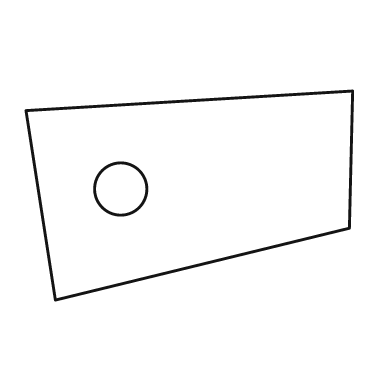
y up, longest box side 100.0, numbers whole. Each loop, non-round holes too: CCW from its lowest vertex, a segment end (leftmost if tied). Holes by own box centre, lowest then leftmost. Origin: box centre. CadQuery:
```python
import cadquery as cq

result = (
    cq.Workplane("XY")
    .moveTo(-41.0, -32.0)
    .lineTo(49.0, -10.0)
    .lineTo(50.0, 32.0)
    .lineTo(-50.0, 26.0)
    .close()
    .moveTo(-21.0, 2.0)
    .circle(8.0)
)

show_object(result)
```